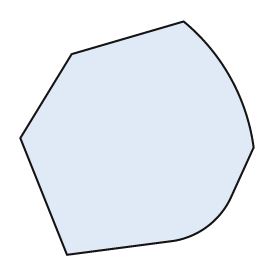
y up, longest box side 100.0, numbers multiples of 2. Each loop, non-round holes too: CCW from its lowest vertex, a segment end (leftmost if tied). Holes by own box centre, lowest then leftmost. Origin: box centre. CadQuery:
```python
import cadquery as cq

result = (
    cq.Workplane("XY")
    .moveTo(-30.0, -50.0)
    .lineTo(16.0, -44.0)
    .threePointArc((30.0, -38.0), (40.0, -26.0))
    .lineTo(50.0, -4.0)
    .threePointArc((40.0, 26.0), (20.0, 50.0))
    .lineTo(-28.0, 36.0)
    .lineTo(-50.0, 0.0)
    .close()
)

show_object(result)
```